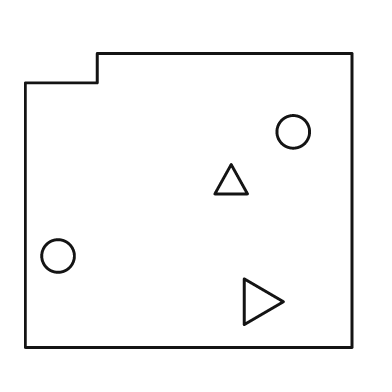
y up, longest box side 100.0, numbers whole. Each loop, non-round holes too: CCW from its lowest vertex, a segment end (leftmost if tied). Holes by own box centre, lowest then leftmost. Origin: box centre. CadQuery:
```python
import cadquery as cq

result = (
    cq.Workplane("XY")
    .moveTo(-50.0, -45.0)
    .lineTo(50.0, -45.0)
    .lineTo(50.0, 45.0)
    .lineTo(-28.0, 45.0)
    .lineTo(-28.0, 36.0)
    .lineTo(-50.0, 36.0)
    .close()
    .moveTo(17.0, -38.0)
    .lineTo(29.0, -31.0)
    .lineTo(17.0, -24.0)
    .close()
    .moveTo(-40.0, -17.0)
    .circle(5.0)
    .moveTo(8.0, 2.0)
    .lineTo(18.0, 2.0)
    .lineTo(13.0, 11.0)
    .close()
    .moveTo(32.0, 21.0)
    .circle(5.0)
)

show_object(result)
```